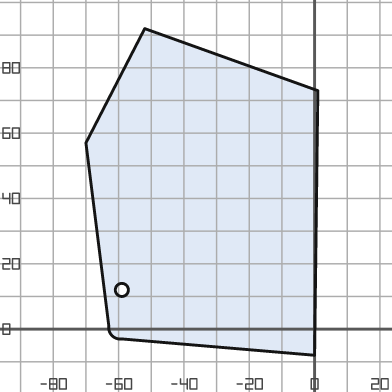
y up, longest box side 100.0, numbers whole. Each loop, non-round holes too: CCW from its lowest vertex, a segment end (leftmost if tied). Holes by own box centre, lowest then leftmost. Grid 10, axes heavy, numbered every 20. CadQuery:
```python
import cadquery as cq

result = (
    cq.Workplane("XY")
    .moveTo(0.0, -8.0)
    .lineTo(1.0, 73.0)
    .lineTo(-52.0, 92.0)
    .lineTo(-70.0, 57.0)
    .lineTo(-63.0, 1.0)
    .threePointArc((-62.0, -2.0), (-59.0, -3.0))
    .close()
    .moveTo(-59.0, 12.0)
    .circle(2.0)
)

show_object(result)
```